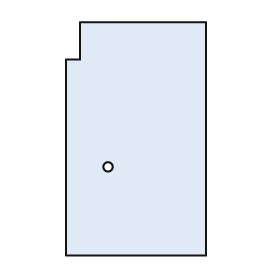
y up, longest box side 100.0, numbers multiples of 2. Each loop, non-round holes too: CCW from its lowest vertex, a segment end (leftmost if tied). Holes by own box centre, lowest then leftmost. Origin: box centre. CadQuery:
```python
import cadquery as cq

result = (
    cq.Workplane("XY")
    .moveTo(-30.0, -50.0)
    .lineTo(30.0, -50.0)
    .lineTo(30.0, 50.0)
    .lineTo(-24.0, 50.0)
    .lineTo(-24.0, 34.0)
    .lineTo(-30.0, 34.0)
    .close()
    .moveTo(-12.0, -12.0)
    .circle(2.0)
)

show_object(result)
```